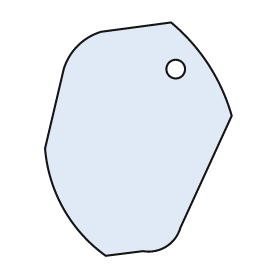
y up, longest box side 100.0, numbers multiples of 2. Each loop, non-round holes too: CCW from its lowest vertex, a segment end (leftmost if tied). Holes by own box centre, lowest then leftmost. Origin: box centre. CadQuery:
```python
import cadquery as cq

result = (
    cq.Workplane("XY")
    .moveTo(-14.0, -50.0)
    .lineTo(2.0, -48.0)
    .threePointArc((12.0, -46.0), (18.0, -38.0))
    .lineTo(40.0, 10.0)
    .threePointArc((30.0, 32.0), (14.0, 50.0))
    .lineTo(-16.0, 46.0)
    .threePointArc((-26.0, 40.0), (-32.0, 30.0))
    .lineTo(-40.0, -4.0)
    .threePointArc((-32.0, -30.0), (-14.0, -50.0))
    .close()
    .moveTo(16.0, 30.0)
    .circle(4.0)
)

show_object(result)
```